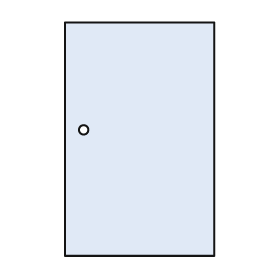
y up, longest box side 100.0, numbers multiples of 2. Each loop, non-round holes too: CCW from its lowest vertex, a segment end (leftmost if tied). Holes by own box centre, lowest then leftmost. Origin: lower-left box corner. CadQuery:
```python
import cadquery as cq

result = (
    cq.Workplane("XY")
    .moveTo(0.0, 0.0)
    .lineTo(64.0, 0.0)
    .lineTo(64.0, 100.0)
    .lineTo(0.0, 100.0)
    .close()
    .moveTo(8.0, 54.0)
    .circle(2.0)
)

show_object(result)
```